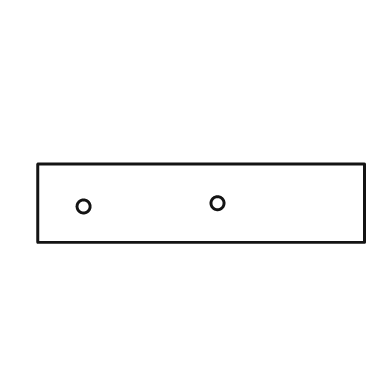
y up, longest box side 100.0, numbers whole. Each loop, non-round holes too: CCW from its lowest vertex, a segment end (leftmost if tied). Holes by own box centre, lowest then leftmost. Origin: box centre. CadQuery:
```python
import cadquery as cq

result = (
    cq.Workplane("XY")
    .moveTo(-50.0, -12.0)
    .lineTo(50.0, -12.0)
    .lineTo(50.0, 12.0)
    .lineTo(-50.0, 12.0)
    .close()
    .moveTo(-36.0, -1.0)
    .circle(2.0)
    .moveTo(5.0, 0.0)
    .circle(2.0)
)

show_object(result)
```